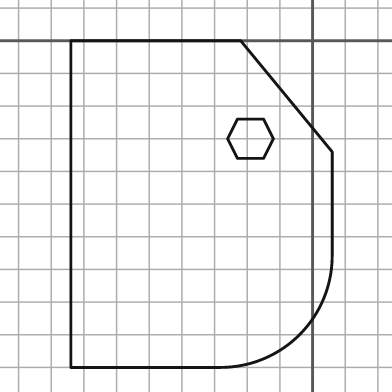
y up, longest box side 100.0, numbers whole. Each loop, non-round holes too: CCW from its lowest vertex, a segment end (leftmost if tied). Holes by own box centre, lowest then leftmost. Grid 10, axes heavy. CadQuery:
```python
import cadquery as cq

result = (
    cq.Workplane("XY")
    .moveTo(-74.0, -100.0)
    .lineTo(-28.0, -100.0)
    .threePointArc((-4.0, -90.0), (6.0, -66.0))
    .lineTo(6.0, -34.0)
    .lineTo(-22.0, 0.0)
    .lineTo(-74.0, 0.0)
    .close()
    .moveTo(-23.0, -36.0)
    .lineTo(-15.0, -36.0)
    .lineTo(-12.0, -30.0)
    .lineTo(-15.0, -24.0)
    .lineTo(-23.0, -24.0)
    .lineTo(-26.0, -30.0)
    .close()
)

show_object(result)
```